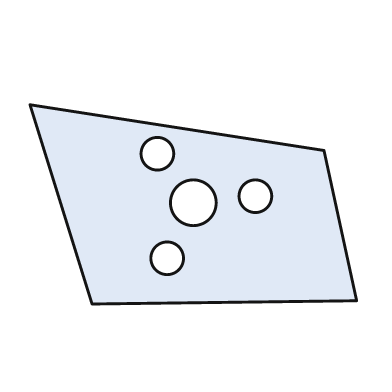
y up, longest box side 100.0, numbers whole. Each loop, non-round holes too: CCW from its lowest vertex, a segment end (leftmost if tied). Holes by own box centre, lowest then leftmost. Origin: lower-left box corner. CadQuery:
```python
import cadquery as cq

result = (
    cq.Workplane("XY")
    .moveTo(19.0, 0.0)
    .lineTo(100.0, 1.0)
    .lineTo(90.0, 47.0)
    .lineTo(0.0, 61.0)
    .close()
    .moveTo(42.0, 14.0)
    .circle(5.0)
    .moveTo(50.0, 31.0)
    .circle(7.0)
    .moveTo(69.0, 33.0)
    .circle(5.0)
    .moveTo(39.0, 46.0)
    .circle(5.0)
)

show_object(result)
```